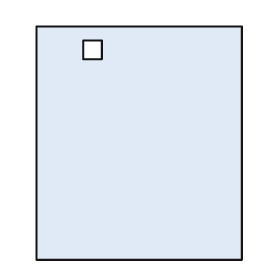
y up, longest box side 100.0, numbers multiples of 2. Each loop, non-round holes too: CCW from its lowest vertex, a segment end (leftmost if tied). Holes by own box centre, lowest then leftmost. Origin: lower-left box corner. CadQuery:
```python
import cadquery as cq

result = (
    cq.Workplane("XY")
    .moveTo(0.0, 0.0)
    .lineTo(88.0, 0.0)
    .lineTo(88.0, 100.0)
    .lineTo(0.0, 100.0)
    .close()
    .moveTo(20.0, 86.0)
    .lineTo(28.0, 86.0)
    .lineTo(28.0, 94.0)
    .lineTo(20.0, 94.0)
    .close()
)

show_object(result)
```